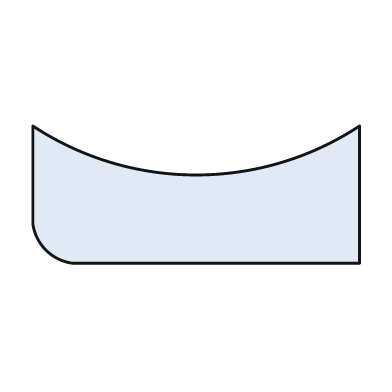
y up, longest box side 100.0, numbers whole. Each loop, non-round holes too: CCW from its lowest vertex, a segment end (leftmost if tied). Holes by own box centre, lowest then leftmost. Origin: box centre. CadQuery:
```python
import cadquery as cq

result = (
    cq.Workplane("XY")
    .moveTo(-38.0, -21.0)
    .lineTo(50.0, -21.0)
    .lineTo(50.0, 21.0)
    .threePointArc((0.0, 6.0), (-50.0, 21.0))
    .lineTo(-50.0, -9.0)
    .threePointArc((-46.0, -17.0), (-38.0, -21.0))
    .close()
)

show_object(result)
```